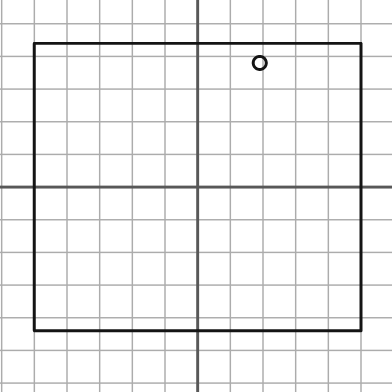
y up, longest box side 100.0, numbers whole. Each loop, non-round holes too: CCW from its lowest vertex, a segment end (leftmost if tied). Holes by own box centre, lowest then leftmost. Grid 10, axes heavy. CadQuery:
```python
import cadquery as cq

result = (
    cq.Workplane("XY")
    .moveTo(-50.0, -44.0)
    .lineTo(50.0, -44.0)
    .lineTo(50.0, 44.0)
    .lineTo(-50.0, 44.0)
    .close()
    .moveTo(19.0, 38.0)
    .circle(2.0)
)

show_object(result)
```